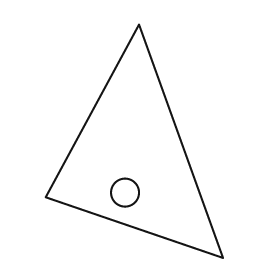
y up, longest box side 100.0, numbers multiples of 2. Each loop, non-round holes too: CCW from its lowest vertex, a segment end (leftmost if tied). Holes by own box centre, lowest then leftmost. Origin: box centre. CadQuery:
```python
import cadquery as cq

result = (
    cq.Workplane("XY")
    .moveTo(38.0, -50.0)
    .lineTo(2.0, 50.0)
    .lineTo(-38.0, -24.0)
    .close()
    .moveTo(-4.0, -22.0)
    .circle(6.0)
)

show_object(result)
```